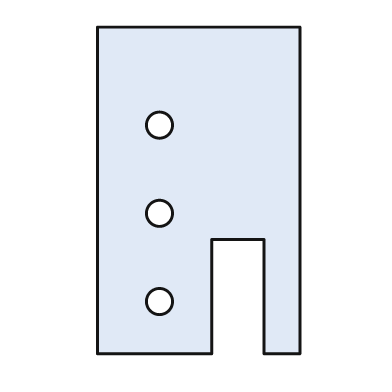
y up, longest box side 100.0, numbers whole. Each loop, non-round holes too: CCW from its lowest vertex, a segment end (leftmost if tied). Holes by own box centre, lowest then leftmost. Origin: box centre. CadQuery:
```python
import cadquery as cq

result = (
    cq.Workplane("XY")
    .moveTo(-31.0, -50.0)
    .lineTo(4.0, -50.0)
    .lineTo(4.0, -15.0)
    .lineTo(20.0, -15.0)
    .lineTo(20.0, -50.0)
    .lineTo(31.0, -50.0)
    .lineTo(31.0, 50.0)
    .lineTo(-31.0, 50.0)
    .close()
    .moveTo(-12.0, -34.0)
    .circle(4.0)
    .moveTo(-12.0, -7.0)
    .circle(4.0)
    .moveTo(-12.0, 20.0)
    .circle(4.0)
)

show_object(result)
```